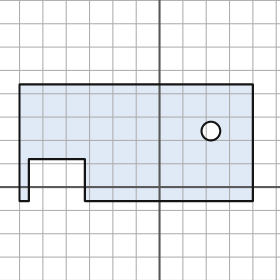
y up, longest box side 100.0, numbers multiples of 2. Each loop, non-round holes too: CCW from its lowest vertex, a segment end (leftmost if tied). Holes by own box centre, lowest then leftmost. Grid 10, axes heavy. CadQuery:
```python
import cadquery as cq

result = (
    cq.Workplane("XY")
    .moveTo(-60.0, -6.0)
    .lineTo(-56.0, -6.0)
    .lineTo(-56.0, 12.0)
    .lineTo(-32.0, 12.0)
    .lineTo(-32.0, -6.0)
    .lineTo(40.0, -6.0)
    .lineTo(40.0, 44.0)
    .lineTo(-60.0, 44.0)
    .close()
    .moveTo(22.0, 24.0)
    .circle(4.0)
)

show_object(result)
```